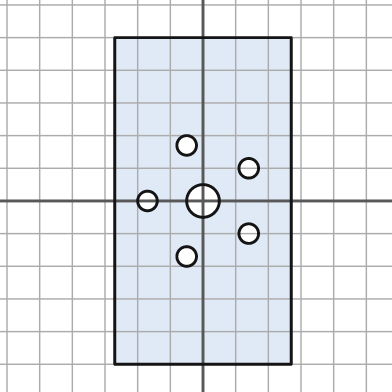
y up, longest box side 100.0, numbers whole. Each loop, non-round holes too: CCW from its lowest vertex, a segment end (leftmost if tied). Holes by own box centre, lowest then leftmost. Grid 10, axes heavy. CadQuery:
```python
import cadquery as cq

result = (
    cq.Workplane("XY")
    .moveTo(-27.0, -50.0)
    .lineTo(27.0, -50.0)
    .lineTo(27.0, 50.0)
    .lineTo(-27.0, 50.0)
    .close()
    .moveTo(-5.0, -17.0)
    .circle(3.0)
    .moveTo(14.0, -10.0)
    .circle(3.0)
    .moveTo(-17.0, 0.0)
    .circle(3.0)
    .moveTo(0.0, 0.0)
    .circle(5.0)
    .moveTo(14.0, 10.0)
    .circle(3.0)
    .moveTo(-5.0, 17.0)
    .circle(3.0)
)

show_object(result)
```